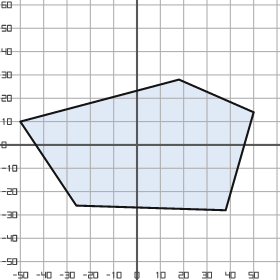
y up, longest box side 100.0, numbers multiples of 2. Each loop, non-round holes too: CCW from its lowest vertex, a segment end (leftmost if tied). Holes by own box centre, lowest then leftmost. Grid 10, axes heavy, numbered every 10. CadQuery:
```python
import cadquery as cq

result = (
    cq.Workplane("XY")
    .moveTo(38.0, -28.0)
    .lineTo(50.0, 14.0)
    .lineTo(18.0, 28.0)
    .lineTo(-50.0, 10.0)
    .lineTo(-26.0, -26.0)
    .close()
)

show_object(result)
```